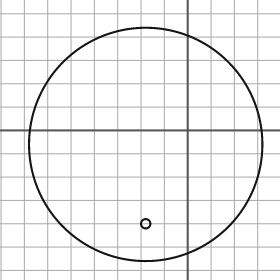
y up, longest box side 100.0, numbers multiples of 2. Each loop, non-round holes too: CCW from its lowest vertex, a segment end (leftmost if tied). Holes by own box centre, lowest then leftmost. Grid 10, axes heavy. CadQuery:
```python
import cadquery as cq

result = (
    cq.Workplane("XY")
    .moveTo(-18.0, -6.0)
    .circle(50.0)
    .moveTo(-18.0, -40.0)
    .circle(2.0)
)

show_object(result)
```